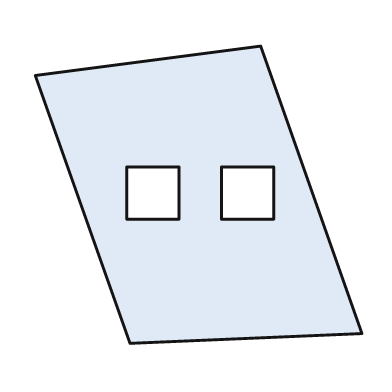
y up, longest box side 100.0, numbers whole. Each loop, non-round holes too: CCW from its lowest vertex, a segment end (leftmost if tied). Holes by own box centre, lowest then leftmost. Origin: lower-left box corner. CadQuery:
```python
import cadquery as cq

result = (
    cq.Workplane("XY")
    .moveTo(29.0, 0.0)
    .lineTo(100.0, 3.0)
    .lineTo(69.0, 91.0)
    .lineTo(0.0, 82.0)
    .close()
    .moveTo(28.0, 38.0)
    .lineTo(44.0, 38.0)
    .lineTo(44.0, 54.0)
    .lineTo(28.0, 54.0)
    .close()
    .moveTo(57.0, 38.0)
    .lineTo(73.0, 38.0)
    .lineTo(73.0, 54.0)
    .lineTo(57.0, 54.0)
    .close()
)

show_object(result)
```